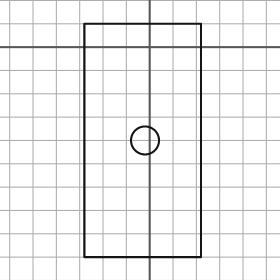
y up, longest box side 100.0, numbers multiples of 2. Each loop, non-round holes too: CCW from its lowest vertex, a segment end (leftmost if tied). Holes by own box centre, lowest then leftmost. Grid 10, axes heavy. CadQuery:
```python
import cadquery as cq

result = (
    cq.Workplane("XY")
    .moveTo(-28.0, -90.0)
    .lineTo(22.0, -90.0)
    .lineTo(22.0, 10.0)
    .lineTo(-28.0, 10.0)
    .close()
    .moveTo(-2.0, -40.0)
    .circle(6.0)
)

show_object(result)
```